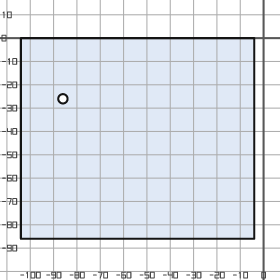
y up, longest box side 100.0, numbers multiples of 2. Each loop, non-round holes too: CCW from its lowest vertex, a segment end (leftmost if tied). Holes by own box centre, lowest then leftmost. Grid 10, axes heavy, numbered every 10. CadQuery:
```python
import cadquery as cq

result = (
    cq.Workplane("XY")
    .moveTo(-104.0, -86.0)
    .lineTo(-4.0, -86.0)
    .lineTo(-4.0, 0.0)
    .lineTo(-104.0, 0.0)
    .close()
    .moveTo(-86.0, -26.0)
    .circle(2.0)
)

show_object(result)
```